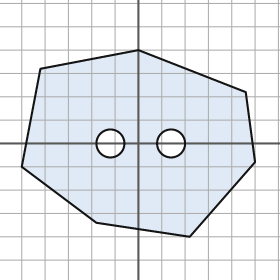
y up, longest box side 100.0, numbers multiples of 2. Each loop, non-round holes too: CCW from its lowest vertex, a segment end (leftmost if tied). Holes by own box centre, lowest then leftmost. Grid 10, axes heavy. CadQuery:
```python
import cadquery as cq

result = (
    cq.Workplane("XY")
    .moveTo(22.0, -40.0)
    .lineTo(50.0, -8.0)
    .lineTo(46.0, 22.0)
    .lineTo(0.0, 40.0)
    .lineTo(-42.0, 32.0)
    .lineTo(-50.0, -10.0)
    .lineTo(-18.0, -34.0)
    .close()
    .moveTo(-12.0, 0.0)
    .circle(6.0)
    .moveTo(14.0, 0.0)
    .circle(6.0)
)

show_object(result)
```